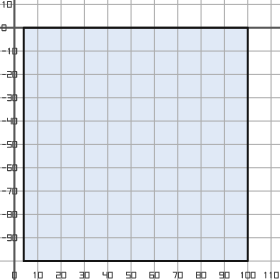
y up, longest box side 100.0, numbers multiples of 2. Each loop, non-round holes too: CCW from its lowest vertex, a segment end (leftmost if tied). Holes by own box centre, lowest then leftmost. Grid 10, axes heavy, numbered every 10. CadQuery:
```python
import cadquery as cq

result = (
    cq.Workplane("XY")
    .moveTo(4.0, -100.0)
    .lineTo(100.0, -100.0)
    .lineTo(100.0, 0.0)
    .lineTo(4.0, 0.0)
    .close()
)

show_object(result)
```